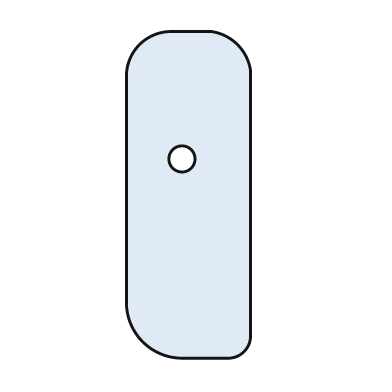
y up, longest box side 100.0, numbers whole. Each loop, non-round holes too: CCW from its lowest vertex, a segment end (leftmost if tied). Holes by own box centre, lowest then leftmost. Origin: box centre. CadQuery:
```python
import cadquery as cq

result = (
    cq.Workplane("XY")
    .moveTo(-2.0, -50.0)
    .lineTo(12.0, -50.0)
    .threePointArc((17.0, -48.0), (19.0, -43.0))
    .lineTo(19.0, 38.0)
    .threePointArc((15.0, 46.0), (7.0, 50.0))
    .lineTo(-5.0, 50.0)
    .threePointArc((-15.0, 46.0), (-19.0, 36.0))
    .lineTo(-19.0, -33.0)
    .threePointArc((-14.0, -45.0), (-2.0, -50.0))
    .close()
    .moveTo(-2.0, 11.0)
    .circle(4.0)
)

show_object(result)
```